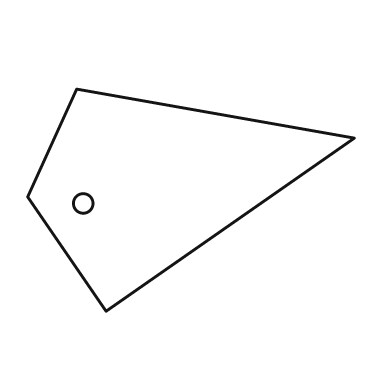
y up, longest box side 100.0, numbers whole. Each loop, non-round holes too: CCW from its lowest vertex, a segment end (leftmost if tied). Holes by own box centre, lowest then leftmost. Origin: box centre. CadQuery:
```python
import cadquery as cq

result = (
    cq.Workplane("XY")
    .moveTo(-26.0, -34.0)
    .lineTo(50.0, 19.0)
    .lineTo(-35.0, 34.0)
    .lineTo(-50.0, 1.0)
    .close()
    .moveTo(-33.0, -1.0)
    .circle(3.0)
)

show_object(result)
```